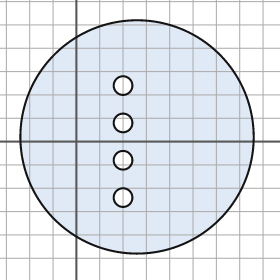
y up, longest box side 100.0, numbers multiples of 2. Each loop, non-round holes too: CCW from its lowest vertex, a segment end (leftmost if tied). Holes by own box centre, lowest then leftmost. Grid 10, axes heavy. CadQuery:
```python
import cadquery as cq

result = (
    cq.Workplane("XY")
    .moveTo(26.0, 2.0)
    .circle(50.0)
    .moveTo(20.0, -24.0)
    .circle(4.0)
    .moveTo(20.0, -8.0)
    .circle(4.0)
    .moveTo(20.0, 8.0)
    .circle(4.0)
    .moveTo(20.0, 24.0)
    .circle(4.0)
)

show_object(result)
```